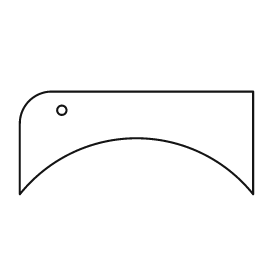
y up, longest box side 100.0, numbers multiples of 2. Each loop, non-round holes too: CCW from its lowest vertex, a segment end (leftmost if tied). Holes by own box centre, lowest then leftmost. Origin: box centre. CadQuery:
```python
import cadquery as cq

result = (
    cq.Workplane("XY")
    .moveTo(-50.0, -22.0)
    .threePointArc((0.0, 2.0), (50.0, -22.0))
    .lineTo(50.0, 22.0)
    .lineTo(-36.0, 22.0)
    .threePointArc((-46.0, 18.0), (-50.0, 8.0))
    .close()
    .moveTo(-32.0, 14.0)
    .circle(2.0)
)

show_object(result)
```